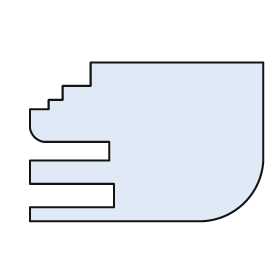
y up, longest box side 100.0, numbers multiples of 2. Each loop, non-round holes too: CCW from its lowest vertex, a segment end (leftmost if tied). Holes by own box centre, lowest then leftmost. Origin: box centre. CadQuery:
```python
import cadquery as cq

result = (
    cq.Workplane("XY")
    .moveTo(-50.0, -34.0)
    .lineTo(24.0, -34.0)
    .threePointArc((42.0, -26.0), (50.0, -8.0))
    .lineTo(50.0, 34.0)
    .lineTo(-24.0, 34.0)
    .lineTo(-24.0, 24.0)
    .lineTo(-36.0, 24.0)
    .lineTo(-36.0, 18.0)
    .lineTo(-42.0, 18.0)
    .lineTo(-42.0, 14.0)
    .lineTo(-50.0, 14.0)
    .lineTo(-50.0, 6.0)
    .threePointArc((-48.0, 2.0), (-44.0, 0.0))
    .lineTo(-16.0, 0.0)
    .lineTo(-16.0, -8.0)
    .lineTo(-50.0, -8.0)
    .lineTo(-50.0, -18.0)
    .lineTo(-14.0, -18.0)
    .lineTo(-14.0, -28.0)
    .lineTo(-50.0, -28.0)
    .close()
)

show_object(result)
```